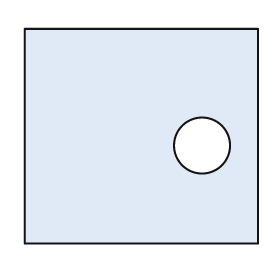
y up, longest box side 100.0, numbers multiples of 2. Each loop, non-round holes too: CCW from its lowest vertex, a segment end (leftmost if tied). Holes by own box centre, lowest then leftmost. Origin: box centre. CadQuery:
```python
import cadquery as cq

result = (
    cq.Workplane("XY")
    .moveTo(-50.0, -46.0)
    .lineTo(50.0, -46.0)
    .lineTo(50.0, 46.0)
    .lineTo(-50.0, 46.0)
    .close()
    .moveTo(26.0, -4.0)
    .circle(12.0)
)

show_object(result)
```